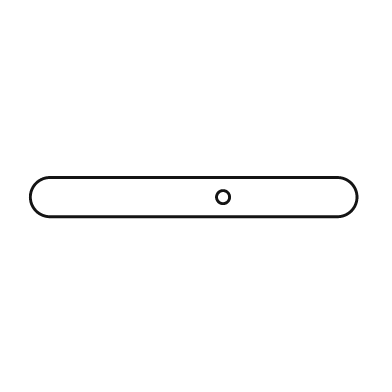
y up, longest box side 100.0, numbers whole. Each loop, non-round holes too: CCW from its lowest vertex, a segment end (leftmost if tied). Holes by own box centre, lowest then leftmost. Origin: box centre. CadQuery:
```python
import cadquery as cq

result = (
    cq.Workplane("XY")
    .moveTo(-44.0, -6.0)
    .lineTo(44.0, -6.0)
    .threePointArc((50.0, 0.0), (44.0, 6.0))
    .lineTo(-44.0, 6.0)
    .threePointArc((-50.0, 0.0), (-44.0, -6.0))
    .close()
    .moveTo(9.0, 0.0)
    .circle(2.0)
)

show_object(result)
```